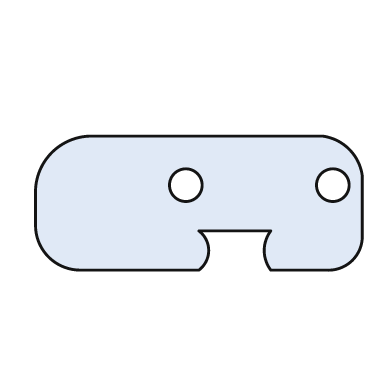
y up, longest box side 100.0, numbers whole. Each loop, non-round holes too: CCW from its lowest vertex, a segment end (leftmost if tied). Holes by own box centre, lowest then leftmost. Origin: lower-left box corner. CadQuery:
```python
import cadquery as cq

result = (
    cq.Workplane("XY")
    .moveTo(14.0, 0.0)
    .lineTo(50.0, 0.0)
    .threePointArc((53.0, 6.0), (50.0, 12.0))
    .lineTo(72.0, 12.0)
    .threePointArc((70.0, 6.0), (72.0, 0.0))
    .lineTo(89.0, 0.0)
    .threePointArc((97.0, 3.0), (100.0, 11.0))
    .lineTo(100.0, 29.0)
    .threePointArc((96.0, 37.0), (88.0, 41.0))
    .lineTo(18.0, 41.0)
    .threePointArc((5.0, 36.0), (0.0, 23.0))
    .lineTo(0.0, 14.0)
    .threePointArc((4.0, 4.0), (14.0, 0.0))
    .close()
    .moveTo(46.0, 26.0)
    .circle(5.0)
    .moveTo(91.0, 26.0)
    .circle(5.0)
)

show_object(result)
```